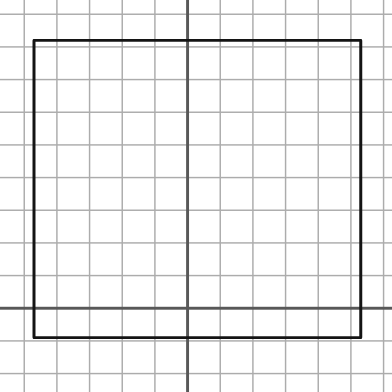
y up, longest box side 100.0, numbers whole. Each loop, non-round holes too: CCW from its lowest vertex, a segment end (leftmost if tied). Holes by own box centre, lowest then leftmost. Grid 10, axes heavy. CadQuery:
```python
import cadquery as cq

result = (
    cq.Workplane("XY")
    .moveTo(-47.0, -9.0)
    .lineTo(53.0, -9.0)
    .lineTo(53.0, 82.0)
    .lineTo(-47.0, 82.0)
    .close()
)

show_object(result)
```